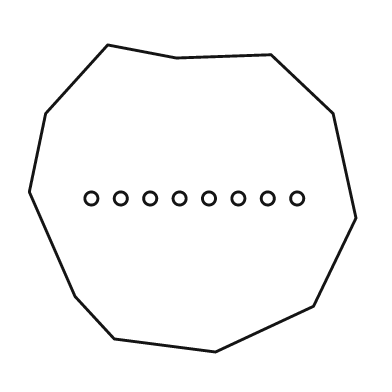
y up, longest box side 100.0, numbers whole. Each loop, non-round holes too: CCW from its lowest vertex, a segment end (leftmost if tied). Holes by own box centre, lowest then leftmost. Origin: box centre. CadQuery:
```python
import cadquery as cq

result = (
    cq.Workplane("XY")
    .moveTo(7.0, -47.0)
    .lineTo(37.0, -33.0)
    .lineTo(50.0, -6.0)
    .lineTo(43.0, 26.0)
    .lineTo(24.0, 44.0)
    .lineTo(-5.0, 43.0)
    .lineTo(-26.0, 47.0)
    .lineTo(-45.0, 26.0)
    .lineTo(-50.0, 2.0)
    .lineTo(-36.0, -30.0)
    .lineTo(-24.0, -43.0)
    .close()
    .moveTo(-31.0, 0.0)
    .circle(2.0)
    .moveTo(-22.0, 0.0)
    .circle(2.0)
    .moveTo(-13.0, 0.0)
    .circle(2.0)
    .moveTo(-4.0, 0.0)
    .circle(2.0)
    .moveTo(5.0, 0.0)
    .circle(2.0)
    .moveTo(14.0, 0.0)
    .circle(2.0)
    .moveTo(23.0, 0.0)
    .circle(2.0)
    .moveTo(32.0, 0.0)
    .circle(2.0)
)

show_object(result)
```